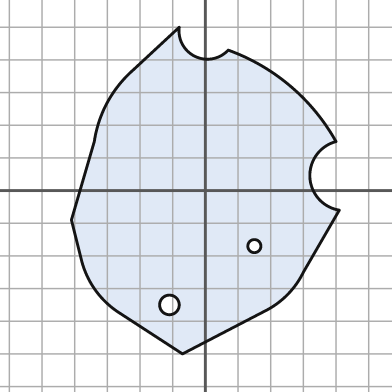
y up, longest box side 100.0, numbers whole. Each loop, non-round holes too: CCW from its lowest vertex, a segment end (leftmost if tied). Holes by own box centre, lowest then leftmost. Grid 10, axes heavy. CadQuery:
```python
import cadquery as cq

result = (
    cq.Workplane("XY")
    .moveTo(-7.0, -50.0)
    .lineTo(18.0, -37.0)
    .threePointArc((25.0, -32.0), (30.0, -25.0))
    .lineTo(41.0, -6.0)
    .threePointArc((32.0, 4.0), (40.0, 15.0))
    .threePointArc((26.0, 32.0), (7.0, 43.0))
    .threePointArc((-3.0, 41.0), (-8.0, 50.0))
    .lineTo(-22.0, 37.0)
    .threePointArc((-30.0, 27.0), (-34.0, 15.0))
    .lineTo(-41.0, -9.0)
    .lineTo(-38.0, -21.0)
    .threePointArc((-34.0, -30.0), (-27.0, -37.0))
    .close()
    .moveTo(-11.0, -35.0)
    .circle(3.0)
    .moveTo(15.0, -17.0)
    .circle(2.0)
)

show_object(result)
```